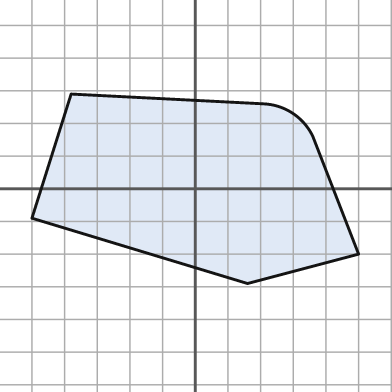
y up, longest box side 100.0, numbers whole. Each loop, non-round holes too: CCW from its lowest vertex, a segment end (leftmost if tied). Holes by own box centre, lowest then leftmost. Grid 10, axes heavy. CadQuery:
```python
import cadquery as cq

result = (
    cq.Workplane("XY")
    .moveTo(16.0, -29.0)
    .lineTo(50.0, -20.0)
    .lineTo(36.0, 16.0)
    .threePointArc((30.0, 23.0), (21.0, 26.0))
    .lineTo(-38.0, 29.0)
    .lineTo(-50.0, -9.0)
    .close()
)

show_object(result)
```